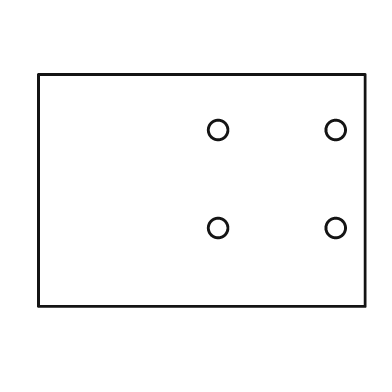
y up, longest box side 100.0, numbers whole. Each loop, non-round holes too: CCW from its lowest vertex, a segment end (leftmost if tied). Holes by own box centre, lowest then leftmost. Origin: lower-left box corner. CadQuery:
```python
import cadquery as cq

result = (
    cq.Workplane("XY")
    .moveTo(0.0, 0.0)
    .lineTo(100.0, 0.0)
    .lineTo(100.0, 71.0)
    .lineTo(0.0, 71.0)
    .close()
    .moveTo(55.0, 24.0)
    .circle(3.0)
    .moveTo(91.0, 24.0)
    .circle(3.0)
    .moveTo(55.0, 54.0)
    .circle(3.0)
    .moveTo(91.0, 54.0)
    .circle(3.0)
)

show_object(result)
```